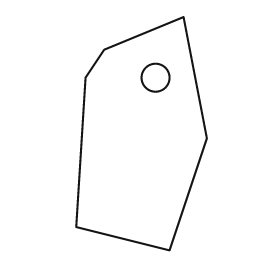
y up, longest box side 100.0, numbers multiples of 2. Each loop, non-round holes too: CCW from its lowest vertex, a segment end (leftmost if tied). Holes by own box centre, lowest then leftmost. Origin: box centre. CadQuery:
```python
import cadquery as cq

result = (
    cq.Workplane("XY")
    .moveTo(12.0, -50.0)
    .lineTo(28.0, -2.0)
    .lineTo(18.0, 50.0)
    .lineTo(-16.0, 36.0)
    .lineTo(-24.0, 24.0)
    .lineTo(-28.0, -40.0)
    .close()
    .moveTo(6.0, 24.0)
    .circle(6.0)
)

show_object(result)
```